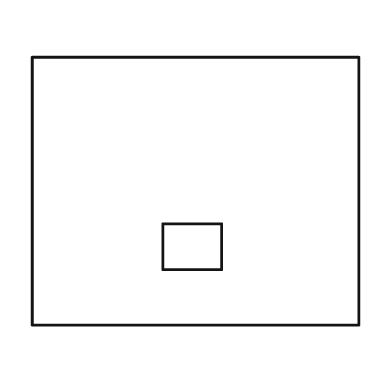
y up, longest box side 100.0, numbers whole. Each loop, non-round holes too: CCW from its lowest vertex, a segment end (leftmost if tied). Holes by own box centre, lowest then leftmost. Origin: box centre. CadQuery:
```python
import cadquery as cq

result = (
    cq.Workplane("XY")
    .moveTo(-50.0, -41.0)
    .lineTo(50.0, -41.0)
    .lineTo(50.0, 41.0)
    .lineTo(-50.0, 41.0)
    .close()
    .moveTo(-10.0, -24.0)
    .lineTo(8.0, -24.0)
    .lineTo(8.0, -10.0)
    .lineTo(-10.0, -10.0)
    .close()
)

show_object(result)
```